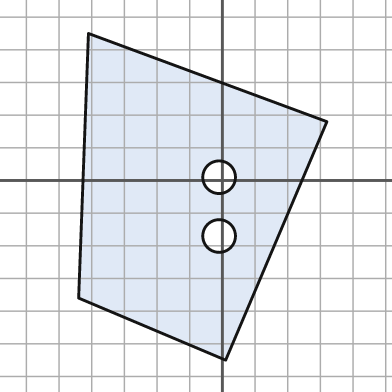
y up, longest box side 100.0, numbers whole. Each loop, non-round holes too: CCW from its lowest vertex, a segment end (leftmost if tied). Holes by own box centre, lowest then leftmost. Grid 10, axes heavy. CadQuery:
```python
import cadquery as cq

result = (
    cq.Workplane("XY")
    .moveTo(1.0, -55.0)
    .lineTo(32.0, 18.0)
    .lineTo(-41.0, 45.0)
    .lineTo(-44.0, -36.0)
    .close()
    .moveTo(-1.0, -17.0)
    .circle(5.0)
    .moveTo(-1.0, 1.0)
    .circle(5.0)
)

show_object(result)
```